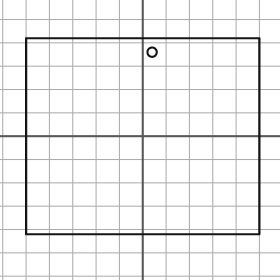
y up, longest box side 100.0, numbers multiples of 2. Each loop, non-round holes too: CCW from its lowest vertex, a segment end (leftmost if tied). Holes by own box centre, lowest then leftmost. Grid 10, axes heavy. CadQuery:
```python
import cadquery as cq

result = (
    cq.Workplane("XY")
    .moveTo(-50.0, -42.0)
    .lineTo(50.0, -42.0)
    .lineTo(50.0, 42.0)
    .lineTo(-50.0, 42.0)
    .close()
    .moveTo(4.0, 36.0)
    .circle(2.0)
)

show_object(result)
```